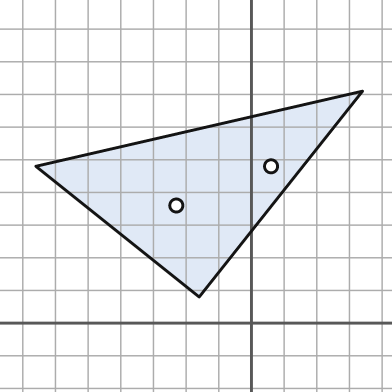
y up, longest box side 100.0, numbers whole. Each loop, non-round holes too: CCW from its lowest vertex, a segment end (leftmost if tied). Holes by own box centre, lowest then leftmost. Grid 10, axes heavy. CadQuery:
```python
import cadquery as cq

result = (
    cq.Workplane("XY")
    .moveTo(-16.0, 8.0)
    .lineTo(34.0, 71.0)
    .lineTo(-66.0, 48.0)
    .close()
    .moveTo(-23.0, 36.0)
    .circle(2.0)
    .moveTo(6.0, 48.0)
    .circle(2.0)
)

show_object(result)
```